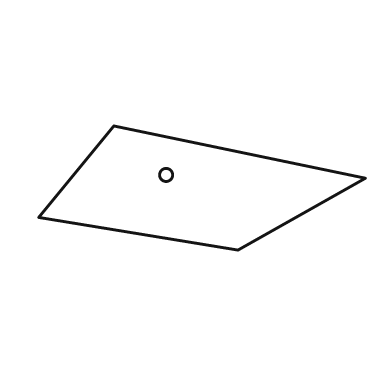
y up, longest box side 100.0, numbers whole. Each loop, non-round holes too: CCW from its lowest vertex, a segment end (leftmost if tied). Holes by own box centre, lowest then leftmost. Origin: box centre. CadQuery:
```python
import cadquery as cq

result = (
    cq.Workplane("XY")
    .moveTo(11.0, -19.0)
    .lineTo(50.0, 3.0)
    .lineTo(-27.0, 19.0)
    .lineTo(-50.0, -9.0)
    .close()
    .moveTo(-11.0, 4.0)
    .circle(2.0)
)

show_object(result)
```